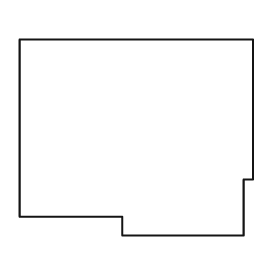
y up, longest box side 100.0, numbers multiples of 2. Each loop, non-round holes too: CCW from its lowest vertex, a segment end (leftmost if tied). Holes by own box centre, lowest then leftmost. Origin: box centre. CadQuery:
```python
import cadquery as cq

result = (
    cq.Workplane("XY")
    .moveTo(-6.0, -42.0)
    .lineTo(46.0, -42.0)
    .lineTo(46.0, -18.0)
    .lineTo(50.0, -18.0)
    .lineTo(50.0, 42.0)
    .lineTo(-50.0, 42.0)
    .lineTo(-50.0, -34.0)
    .lineTo(-6.0, -34.0)
    .close()
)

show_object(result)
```